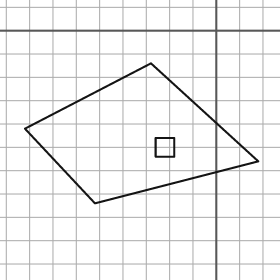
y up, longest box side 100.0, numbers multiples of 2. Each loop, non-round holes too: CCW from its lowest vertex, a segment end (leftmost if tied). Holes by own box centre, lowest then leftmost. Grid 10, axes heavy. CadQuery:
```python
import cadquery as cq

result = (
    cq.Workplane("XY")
    .moveTo(-52.0, -74.0)
    .lineTo(18.0, -56.0)
    .lineTo(-28.0, -14.0)
    .lineTo(-82.0, -42.0)
    .close()
    .moveTo(-26.0, -54.0)
    .lineTo(-18.0, -54.0)
    .lineTo(-18.0, -46.0)
    .lineTo(-26.0, -46.0)
    .close()
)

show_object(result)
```